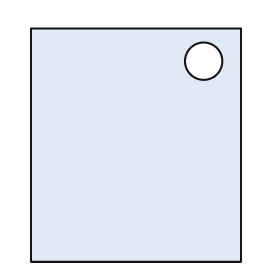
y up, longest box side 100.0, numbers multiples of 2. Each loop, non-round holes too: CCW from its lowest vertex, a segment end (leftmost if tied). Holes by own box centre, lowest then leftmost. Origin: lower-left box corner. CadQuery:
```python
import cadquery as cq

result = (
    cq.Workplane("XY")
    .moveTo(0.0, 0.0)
    .lineTo(90.0, 0.0)
    .lineTo(90.0, 100.0)
    .lineTo(0.0, 100.0)
    .close()
    .moveTo(74.0, 86.0)
    .circle(8.0)
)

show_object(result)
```